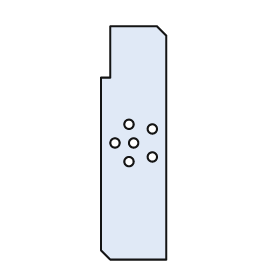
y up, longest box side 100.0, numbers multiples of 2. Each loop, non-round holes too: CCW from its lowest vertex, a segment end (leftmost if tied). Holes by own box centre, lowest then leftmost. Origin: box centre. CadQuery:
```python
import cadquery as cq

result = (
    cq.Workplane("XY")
    .moveTo(-10.0, -50.0)
    .lineTo(14.0, -50.0)
    .lineTo(14.0, 46.0)
    .lineTo(10.0, 50.0)
    .lineTo(-10.0, 50.0)
    .lineTo(-10.0, 28.0)
    .lineTo(-14.0, 28.0)
    .lineTo(-14.0, -46.0)
    .close()
    .moveTo(-2.0, -8.0)
    .circle(2.0)
    .moveTo(8.0, -6.0)
    .circle(2.0)
    .moveTo(-8.0, 0.0)
    .circle(2.0)
    .moveTo(0.0, 0.0)
    .circle(2.0)
    .moveTo(8.0, 6.0)
    .circle(2.0)
    .moveTo(-2.0, 8.0)
    .circle(2.0)
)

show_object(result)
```